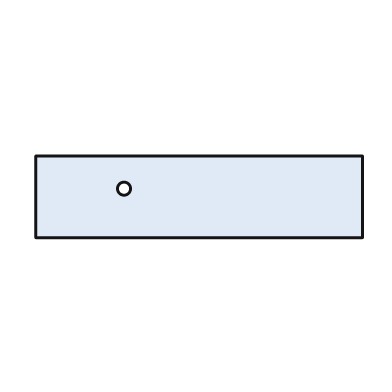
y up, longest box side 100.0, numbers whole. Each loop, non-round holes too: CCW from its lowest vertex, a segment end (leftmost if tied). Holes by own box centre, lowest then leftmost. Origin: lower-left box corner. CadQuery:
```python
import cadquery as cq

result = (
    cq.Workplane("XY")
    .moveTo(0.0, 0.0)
    .lineTo(100.0, 0.0)
    .lineTo(100.0, 25.0)
    .lineTo(0.0, 25.0)
    .close()
    .moveTo(27.0, 15.0)
    .circle(2.0)
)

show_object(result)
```